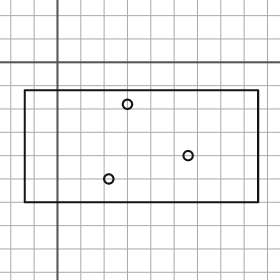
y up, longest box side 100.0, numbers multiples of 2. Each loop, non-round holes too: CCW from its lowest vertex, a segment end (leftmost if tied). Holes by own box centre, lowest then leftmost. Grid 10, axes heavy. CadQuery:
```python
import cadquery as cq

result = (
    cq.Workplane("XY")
    .moveTo(-14.0, -60.0)
    .lineTo(86.0, -60.0)
    .lineTo(86.0, -12.0)
    .lineTo(-14.0, -12.0)
    .close()
    .moveTo(22.0, -50.0)
    .circle(2.0)
    .moveTo(56.0, -40.0)
    .circle(2.0)
    .moveTo(30.0, -18.0)
    .circle(2.0)
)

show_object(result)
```